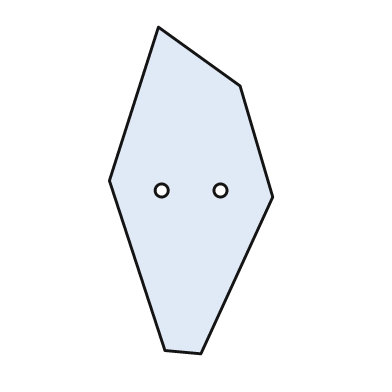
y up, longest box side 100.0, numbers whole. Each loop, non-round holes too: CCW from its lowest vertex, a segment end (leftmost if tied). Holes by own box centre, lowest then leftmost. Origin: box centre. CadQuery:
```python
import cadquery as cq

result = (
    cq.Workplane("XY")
    .moveTo(3.0, -50.0)
    .lineTo(25.0, -2.0)
    .lineTo(15.0, 32.0)
    .lineTo(-10.0, 50.0)
    .lineTo(-25.0, 3.0)
    .lineTo(-8.0, -49.0)
    .close()
    .moveTo(-9.0, 0.0)
    .circle(2.0)
    .moveTo(9.0, 0.0)
    .circle(2.0)
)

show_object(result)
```